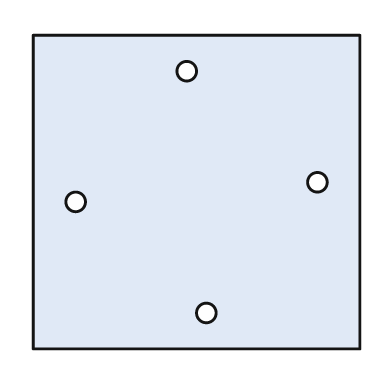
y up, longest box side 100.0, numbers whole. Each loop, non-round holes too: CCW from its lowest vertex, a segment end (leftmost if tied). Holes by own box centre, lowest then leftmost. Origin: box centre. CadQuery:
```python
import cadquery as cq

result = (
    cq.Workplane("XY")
    .moveTo(-50.0, -48.0)
    .lineTo(50.0, -48.0)
    .lineTo(50.0, 48.0)
    .lineTo(-50.0, 48.0)
    .close()
    .moveTo(3.0, -37.0)
    .circle(3.0)
    .moveTo(-37.0, -3.0)
    .circle(3.0)
    .moveTo(37.0, 3.0)
    .circle(3.0)
    .moveTo(-3.0, 37.0)
    .circle(3.0)
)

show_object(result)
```